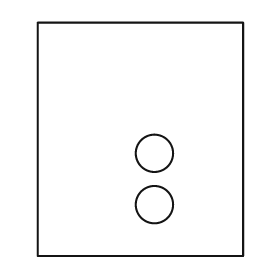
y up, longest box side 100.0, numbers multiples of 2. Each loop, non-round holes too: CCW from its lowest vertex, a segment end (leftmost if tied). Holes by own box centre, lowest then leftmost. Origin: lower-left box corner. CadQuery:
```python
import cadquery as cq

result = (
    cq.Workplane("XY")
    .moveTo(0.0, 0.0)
    .lineTo(88.0, 0.0)
    .lineTo(88.0, 100.0)
    .lineTo(0.0, 100.0)
    .close()
    .moveTo(50.0, 22.0)
    .circle(8.0)
    .moveTo(50.0, 44.0)
    .circle(8.0)
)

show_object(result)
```